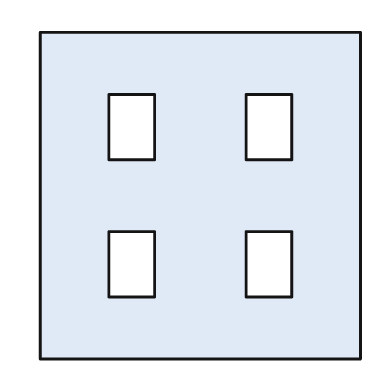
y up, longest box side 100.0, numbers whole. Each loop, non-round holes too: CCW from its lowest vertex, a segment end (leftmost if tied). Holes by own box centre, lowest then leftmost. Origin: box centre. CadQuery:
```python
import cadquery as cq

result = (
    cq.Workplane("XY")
    .moveTo(-49.0, -50.0)
    .lineTo(49.0, -50.0)
    .lineTo(49.0, 50.0)
    .lineTo(-49.0, 50.0)
    .close()
    .moveTo(-28.0, -31.0)
    .lineTo(-14.0, -31.0)
    .lineTo(-14.0, -11.0)
    .lineTo(-28.0, -11.0)
    .close()
    .moveTo(14.0, -31.0)
    .lineTo(28.0, -31.0)
    .lineTo(28.0, -11.0)
    .lineTo(14.0, -11.0)
    .close()
    .moveTo(-28.0, 11.0)
    .lineTo(-14.0, 11.0)
    .lineTo(-14.0, 31.0)
    .lineTo(-28.0, 31.0)
    .close()
    .moveTo(14.0, 11.0)
    .lineTo(28.0, 11.0)
    .lineTo(28.0, 31.0)
    .lineTo(14.0, 31.0)
    .close()
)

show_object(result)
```